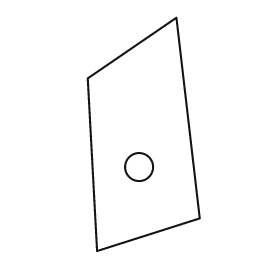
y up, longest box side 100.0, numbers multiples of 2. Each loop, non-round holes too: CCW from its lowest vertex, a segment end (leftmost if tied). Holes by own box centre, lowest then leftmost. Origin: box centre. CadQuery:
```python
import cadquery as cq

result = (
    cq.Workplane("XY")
    .moveTo(-20.0, -50.0)
    .lineTo(24.0, -36.0)
    .lineTo(14.0, 50.0)
    .lineTo(-24.0, 24.0)
    .close()
    .moveTo(-2.0, -14.0)
    .circle(6.0)
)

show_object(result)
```